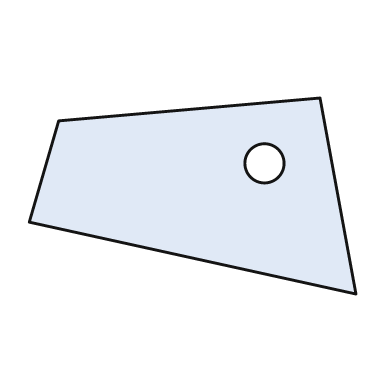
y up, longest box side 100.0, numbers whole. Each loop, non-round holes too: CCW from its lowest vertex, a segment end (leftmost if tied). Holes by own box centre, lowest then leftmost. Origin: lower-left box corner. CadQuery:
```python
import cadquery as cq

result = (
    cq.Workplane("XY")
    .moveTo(100.0, 0.0)
    .lineTo(89.0, 60.0)
    .lineTo(9.0, 53.0)
    .lineTo(0.0, 22.0)
    .close()
    .moveTo(72.0, 40.0)
    .circle(6.0)
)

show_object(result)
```